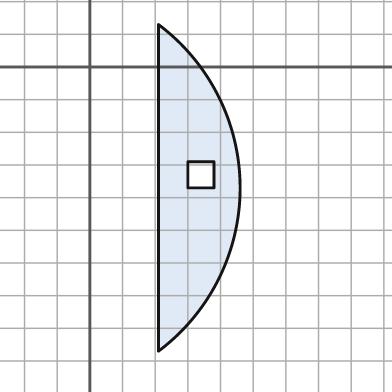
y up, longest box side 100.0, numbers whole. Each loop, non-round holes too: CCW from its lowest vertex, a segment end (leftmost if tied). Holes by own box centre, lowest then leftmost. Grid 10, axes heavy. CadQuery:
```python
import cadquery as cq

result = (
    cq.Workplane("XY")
    .moveTo(21.0, -87.0)
    .threePointArc((46.0, -37.0), (21.0, 13.0))
    .close()
    .moveTo(30.0, -37.0)
    .lineTo(38.0, -37.0)
    .lineTo(38.0, -29.0)
    .lineTo(30.0, -29.0)
    .close()
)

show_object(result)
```